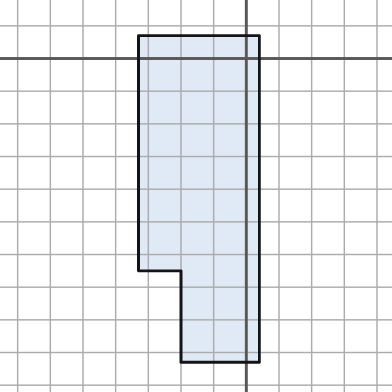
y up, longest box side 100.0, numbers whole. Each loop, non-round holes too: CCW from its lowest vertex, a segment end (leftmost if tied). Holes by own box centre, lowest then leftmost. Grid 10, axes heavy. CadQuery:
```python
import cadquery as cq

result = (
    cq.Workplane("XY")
    .moveTo(-20.0, -93.0)
    .lineTo(4.0, -93.0)
    .lineTo(4.0, 7.0)
    .lineTo(-33.0, 7.0)
    .lineTo(-33.0, -65.0)
    .lineTo(-20.0, -65.0)
    .close()
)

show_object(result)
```